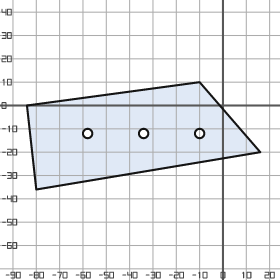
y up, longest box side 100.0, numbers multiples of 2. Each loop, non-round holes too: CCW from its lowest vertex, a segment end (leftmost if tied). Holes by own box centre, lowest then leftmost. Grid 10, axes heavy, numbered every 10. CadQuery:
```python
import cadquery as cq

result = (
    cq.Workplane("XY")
    .moveTo(-80.0, -36.0)
    .lineTo(16.0, -20.0)
    .lineTo(-10.0, 10.0)
    .lineTo(-84.0, 0.0)
    .close()
    .moveTo(-58.0, -12.0)
    .circle(2.0)
    .moveTo(-34.0, -12.0)
    .circle(2.0)
    .moveTo(-10.0, -12.0)
    .circle(2.0)
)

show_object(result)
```